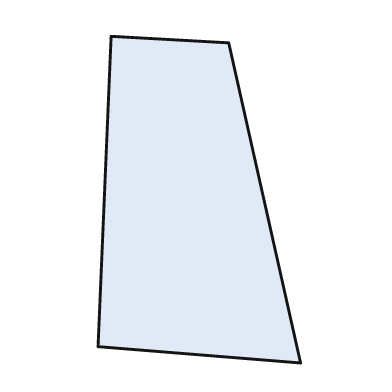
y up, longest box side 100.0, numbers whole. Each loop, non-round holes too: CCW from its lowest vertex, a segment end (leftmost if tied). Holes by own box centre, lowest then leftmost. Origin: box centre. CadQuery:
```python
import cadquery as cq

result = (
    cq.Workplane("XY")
    .moveTo(31.0, -50.0)
    .lineTo(9.0, 48.0)
    .lineTo(-27.0, 50.0)
    .lineTo(-31.0, -45.0)
    .close()
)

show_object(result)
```